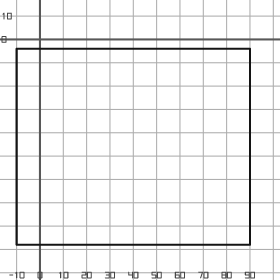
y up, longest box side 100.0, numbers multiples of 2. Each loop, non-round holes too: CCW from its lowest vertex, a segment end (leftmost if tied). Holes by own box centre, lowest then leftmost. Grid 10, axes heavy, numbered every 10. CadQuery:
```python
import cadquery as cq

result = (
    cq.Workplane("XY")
    .moveTo(-10.0, -88.0)
    .lineTo(90.0, -88.0)
    .lineTo(90.0, -4.0)
    .lineTo(-10.0, -4.0)
    .close()
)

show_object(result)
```